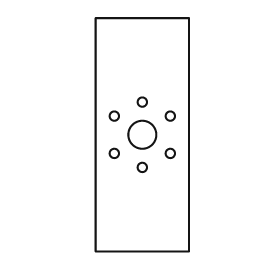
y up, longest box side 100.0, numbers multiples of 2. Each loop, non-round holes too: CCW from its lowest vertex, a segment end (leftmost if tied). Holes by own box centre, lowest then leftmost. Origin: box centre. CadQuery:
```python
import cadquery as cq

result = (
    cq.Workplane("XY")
    .moveTo(-20.0, -50.0)
    .lineTo(20.0, -50.0)
    .lineTo(20.0, 50.0)
    .lineTo(-20.0, 50.0)
    .close()
    .moveTo(0.0, -14.0)
    .circle(2.0)
    .moveTo(-12.0, -8.0)
    .circle(2.0)
    .moveTo(12.0, -8.0)
    .circle(2.0)
    .moveTo(0.0, 0.0)
    .circle(6.0)
    .moveTo(-12.0, 8.0)
    .circle(2.0)
    .moveTo(12.0, 8.0)
    .circle(2.0)
    .moveTo(0.0, 14.0)
    .circle(2.0)
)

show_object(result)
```